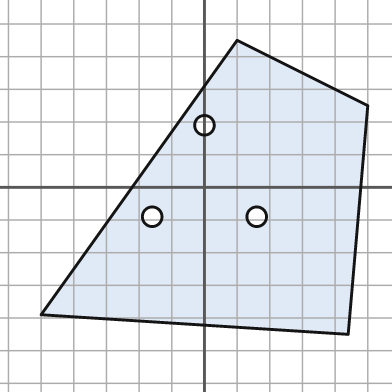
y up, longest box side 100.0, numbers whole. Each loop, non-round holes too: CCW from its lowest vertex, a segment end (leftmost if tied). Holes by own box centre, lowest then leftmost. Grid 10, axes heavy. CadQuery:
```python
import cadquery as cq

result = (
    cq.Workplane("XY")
    .moveTo(44.0, -45.0)
    .lineTo(50.0, 25.0)
    .lineTo(10.0, 45.0)
    .lineTo(-50.0, -39.0)
    .close()
    .moveTo(-16.0, -9.0)
    .circle(3.0)
    .moveTo(16.0, -9.0)
    .circle(3.0)
    .moveTo(0.0, 19.0)
    .circle(3.0)
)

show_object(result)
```